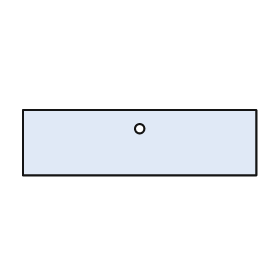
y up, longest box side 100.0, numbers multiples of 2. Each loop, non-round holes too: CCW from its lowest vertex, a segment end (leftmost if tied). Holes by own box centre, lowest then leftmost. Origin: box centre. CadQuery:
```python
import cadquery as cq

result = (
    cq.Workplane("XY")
    .moveTo(-50.0, -14.0)
    .lineTo(50.0, -14.0)
    .lineTo(50.0, 14.0)
    .lineTo(-50.0, 14.0)
    .close()
    .moveTo(0.0, 6.0)
    .circle(2.0)
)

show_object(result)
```